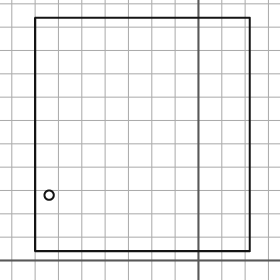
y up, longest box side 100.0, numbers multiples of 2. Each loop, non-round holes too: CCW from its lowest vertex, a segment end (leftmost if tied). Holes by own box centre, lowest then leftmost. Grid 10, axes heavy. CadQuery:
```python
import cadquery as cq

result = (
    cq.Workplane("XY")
    .moveTo(-70.0, 4.0)
    .lineTo(22.0, 4.0)
    .lineTo(22.0, 104.0)
    .lineTo(-70.0, 104.0)
    .close()
    .moveTo(-64.0, 28.0)
    .circle(2.0)
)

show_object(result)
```